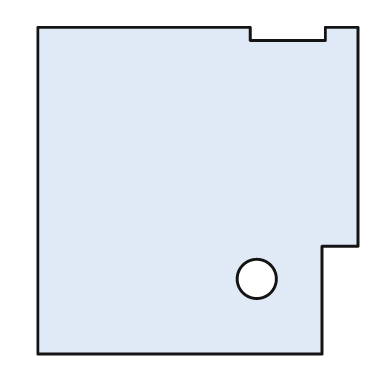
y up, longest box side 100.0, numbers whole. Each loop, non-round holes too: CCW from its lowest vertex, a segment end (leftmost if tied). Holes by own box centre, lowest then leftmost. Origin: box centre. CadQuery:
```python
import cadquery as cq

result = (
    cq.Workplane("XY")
    .moveTo(-49.0, -50.0)
    .lineTo(38.0, -50.0)
    .lineTo(38.0, -17.0)
    .lineTo(49.0, -17.0)
    .lineTo(49.0, 50.0)
    .lineTo(39.0, 50.0)
    .lineTo(39.0, 46.0)
    .lineTo(16.0, 46.0)
    .lineTo(16.0, 50.0)
    .lineTo(-49.0, 50.0)
    .close()
    .moveTo(18.0, -27.0)
    .circle(6.0)
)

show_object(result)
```